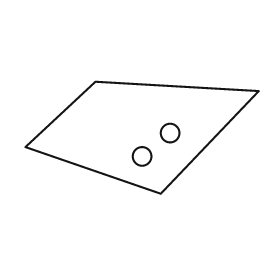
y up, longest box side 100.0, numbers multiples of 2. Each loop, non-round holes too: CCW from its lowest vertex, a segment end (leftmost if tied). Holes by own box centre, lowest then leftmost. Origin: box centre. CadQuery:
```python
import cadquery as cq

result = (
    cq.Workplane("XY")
    .moveTo(8.0, -24.0)
    .lineTo(50.0, 20.0)
    .lineTo(-20.0, 24.0)
    .lineTo(-50.0, -4.0)
    .close()
    .moveTo(0.0, -8.0)
    .circle(4.0)
    .moveTo(12.0, 2.0)
    .circle(4.0)
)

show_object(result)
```